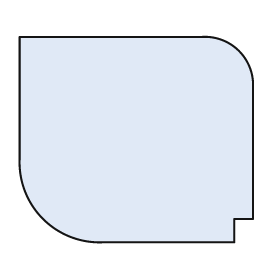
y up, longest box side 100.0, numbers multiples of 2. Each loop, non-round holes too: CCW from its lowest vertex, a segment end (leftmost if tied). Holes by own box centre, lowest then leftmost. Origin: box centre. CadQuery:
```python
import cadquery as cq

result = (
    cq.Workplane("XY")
    .moveTo(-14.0, -44.0)
    .lineTo(42.0, -44.0)
    .lineTo(42.0, -34.0)
    .lineTo(50.0, -34.0)
    .lineTo(50.0, 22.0)
    .threePointArc((44.0, 38.0), (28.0, 44.0))
    .lineTo(-50.0, 44.0)
    .lineTo(-50.0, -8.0)
    .threePointArc((-40.0, -34.0), (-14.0, -44.0))
    .close()
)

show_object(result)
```